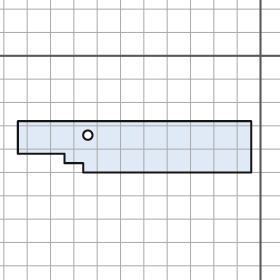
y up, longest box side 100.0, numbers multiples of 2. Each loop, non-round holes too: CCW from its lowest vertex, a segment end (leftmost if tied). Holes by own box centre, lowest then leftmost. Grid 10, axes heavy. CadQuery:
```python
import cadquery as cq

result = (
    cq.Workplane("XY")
    .moveTo(-76.0, -50.0)
    .lineTo(-4.0, -50.0)
    .lineTo(-4.0, -28.0)
    .lineTo(-104.0, -28.0)
    .lineTo(-104.0, -42.0)
    .lineTo(-84.0, -42.0)
    .lineTo(-84.0, -46.0)
    .lineTo(-76.0, -46.0)
    .close()
    .moveTo(-74.0, -34.0)
    .circle(2.0)
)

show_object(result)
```